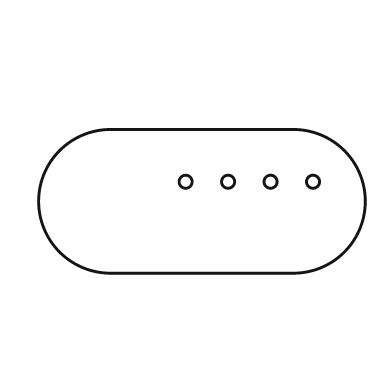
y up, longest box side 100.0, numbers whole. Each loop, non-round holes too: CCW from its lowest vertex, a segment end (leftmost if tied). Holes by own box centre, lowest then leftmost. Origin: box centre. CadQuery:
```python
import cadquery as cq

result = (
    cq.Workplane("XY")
    .moveTo(-28.0, -22.0)
    .lineTo(28.0, -22.0)
    .threePointArc((50.0, 0.0), (28.0, 22.0))
    .lineTo(-28.0, 22.0)
    .threePointArc((-50.0, 0.0), (-28.0, -22.0))
    .close()
    .moveTo(-5.0, 6.0)
    .circle(2.0)
    .moveTo(8.0, 6.0)
    .circle(2.0)
    .moveTo(21.0, 6.0)
    .circle(2.0)
    .moveTo(34.0, 6.0)
    .circle(2.0)
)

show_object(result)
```